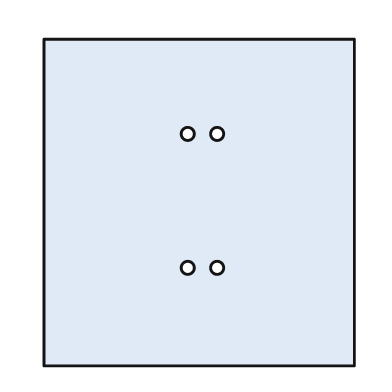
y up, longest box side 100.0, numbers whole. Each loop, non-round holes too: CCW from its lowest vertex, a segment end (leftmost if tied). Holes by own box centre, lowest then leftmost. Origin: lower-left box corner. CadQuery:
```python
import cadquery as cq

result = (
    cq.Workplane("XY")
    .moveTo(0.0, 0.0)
    .lineTo(95.0, 0.0)
    .lineTo(95.0, 100.0)
    .lineTo(0.0, 100.0)
    .close()
    .moveTo(44.0, 30.0)
    .circle(2.0)
    .moveTo(53.0, 30.0)
    .circle(2.0)
    .moveTo(44.0, 71.0)
    .circle(2.0)
    .moveTo(53.0, 71.0)
    .circle(2.0)
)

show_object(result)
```